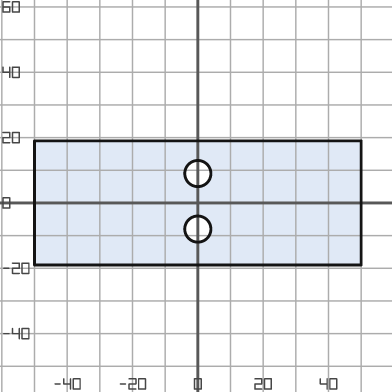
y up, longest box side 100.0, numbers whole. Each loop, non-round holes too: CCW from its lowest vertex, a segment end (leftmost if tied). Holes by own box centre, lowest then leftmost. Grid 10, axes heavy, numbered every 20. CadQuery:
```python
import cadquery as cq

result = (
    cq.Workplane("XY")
    .moveTo(-50.0, -19.0)
    .lineTo(50.0, -19.0)
    .lineTo(50.0, 19.0)
    .lineTo(-50.0, 19.0)
    .close()
    .moveTo(0.0, -8.0)
    .circle(4.0)
    .moveTo(0.0, 9.0)
    .circle(4.0)
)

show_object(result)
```